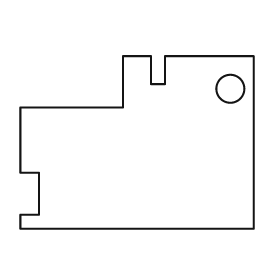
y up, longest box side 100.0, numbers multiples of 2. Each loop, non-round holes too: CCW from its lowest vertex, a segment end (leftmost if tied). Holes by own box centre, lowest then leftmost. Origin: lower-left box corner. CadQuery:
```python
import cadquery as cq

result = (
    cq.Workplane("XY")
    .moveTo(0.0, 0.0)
    .lineTo(100.0, 0.0)
    .lineTo(100.0, 74.0)
    .lineTo(62.0, 74.0)
    .lineTo(62.0, 62.0)
    .lineTo(56.0, 62.0)
    .lineTo(56.0, 74.0)
    .lineTo(44.0, 74.0)
    .lineTo(44.0, 52.0)
    .lineTo(0.0, 52.0)
    .lineTo(0.0, 24.0)
    .lineTo(8.0, 24.0)
    .lineTo(8.0, 6.0)
    .lineTo(0.0, 6.0)
    .close()
    .moveTo(90.0, 60.0)
    .circle(6.0)
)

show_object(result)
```